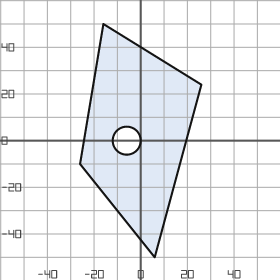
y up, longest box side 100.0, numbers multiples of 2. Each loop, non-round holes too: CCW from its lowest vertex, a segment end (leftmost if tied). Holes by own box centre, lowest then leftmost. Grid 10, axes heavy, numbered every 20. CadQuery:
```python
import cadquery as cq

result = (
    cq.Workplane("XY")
    .moveTo(6.0, -50.0)
    .lineTo(26.0, 24.0)
    .lineTo(-16.0, 50.0)
    .lineTo(-26.0, -10.0)
    .close()
    .moveTo(-6.0, 0.0)
    .circle(6.0)
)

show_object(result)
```